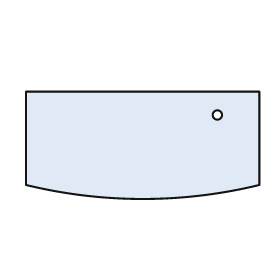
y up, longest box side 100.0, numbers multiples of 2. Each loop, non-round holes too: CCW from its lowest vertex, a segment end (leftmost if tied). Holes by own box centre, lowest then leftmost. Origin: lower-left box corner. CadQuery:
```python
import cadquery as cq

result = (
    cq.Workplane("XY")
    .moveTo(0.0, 6.0)
    .threePointArc((50.0, 0.0), (100.0, 6.0))
    .lineTo(100.0, 46.0)
    .lineTo(0.0, 46.0)
    .close()
    .moveTo(82.0, 36.0)
    .circle(2.0)
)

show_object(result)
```